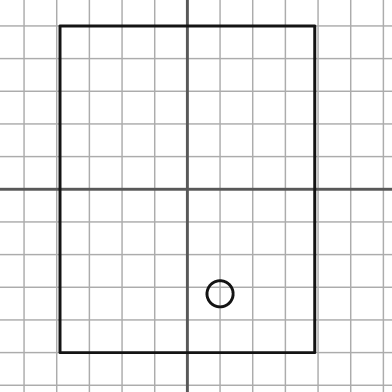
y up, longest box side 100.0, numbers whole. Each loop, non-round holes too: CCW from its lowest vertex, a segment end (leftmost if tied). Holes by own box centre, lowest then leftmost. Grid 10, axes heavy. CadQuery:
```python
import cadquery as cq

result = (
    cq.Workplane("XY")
    .moveTo(-39.0, -50.0)
    .lineTo(39.0, -50.0)
    .lineTo(39.0, 50.0)
    .lineTo(-39.0, 50.0)
    .close()
    .moveTo(10.0, -32.0)
    .circle(4.0)
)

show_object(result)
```